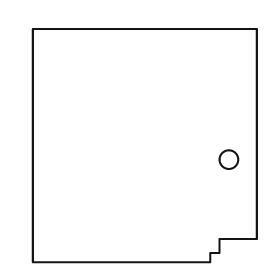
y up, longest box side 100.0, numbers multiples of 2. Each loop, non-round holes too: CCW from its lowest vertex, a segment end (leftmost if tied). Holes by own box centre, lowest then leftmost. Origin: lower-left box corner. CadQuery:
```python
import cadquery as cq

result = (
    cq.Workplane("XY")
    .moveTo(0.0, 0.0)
    .lineTo(76.0, 0.0)
    .lineTo(76.0, 4.0)
    .lineTo(80.0, 4.0)
    .lineTo(80.0, 10.0)
    .lineTo(96.0, 10.0)
    .lineTo(96.0, 100.0)
    .lineTo(0.0, 100.0)
    .close()
    .moveTo(84.0, 44.0)
    .circle(4.0)
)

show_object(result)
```